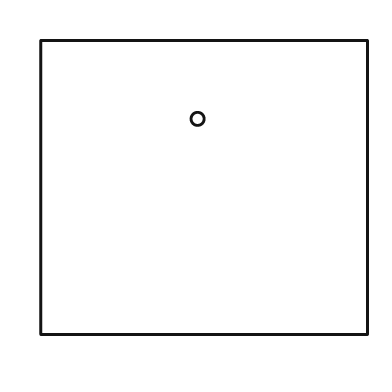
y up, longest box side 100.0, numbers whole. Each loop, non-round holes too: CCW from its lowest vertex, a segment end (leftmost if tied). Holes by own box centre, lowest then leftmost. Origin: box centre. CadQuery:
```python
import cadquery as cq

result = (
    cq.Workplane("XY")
    .moveTo(-50.0, -45.0)
    .lineTo(50.0, -45.0)
    .lineTo(50.0, 45.0)
    .lineTo(-50.0, 45.0)
    .close()
    .moveTo(-2.0, 21.0)
    .circle(2.0)
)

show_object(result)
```